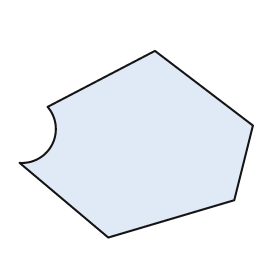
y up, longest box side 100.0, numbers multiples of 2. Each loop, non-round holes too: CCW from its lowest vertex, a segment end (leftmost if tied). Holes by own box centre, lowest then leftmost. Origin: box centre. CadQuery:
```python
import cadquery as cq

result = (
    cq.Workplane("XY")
    .moveTo(-12.0, -40.0)
    .lineTo(42.0, -24.0)
    .lineTo(50.0, 8.0)
    .lineTo(8.0, 40.0)
    .lineTo(-38.0, 16.0)
    .threePointArc((-36.0, 0.0), (-50.0, -8.0))
    .close()
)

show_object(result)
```